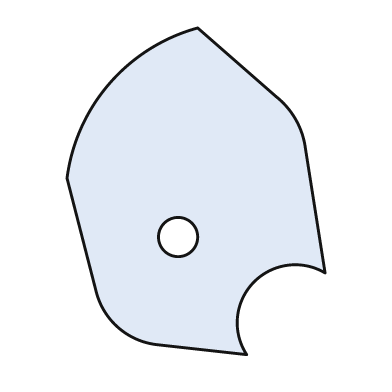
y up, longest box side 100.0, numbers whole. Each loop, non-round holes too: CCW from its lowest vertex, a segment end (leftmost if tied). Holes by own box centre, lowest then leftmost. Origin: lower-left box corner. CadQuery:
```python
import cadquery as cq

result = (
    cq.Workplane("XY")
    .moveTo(55.0, 0.0)
    .threePointArc((57.0, 22.0), (79.0, 25.0))
    .lineTo(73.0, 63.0)
    .threePointArc((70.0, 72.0), (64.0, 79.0))
    .lineTo(40.0, 100.0)
    .threePointArc((13.0, 83.0), (0.0, 54.0))
    .lineTo(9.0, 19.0)
    .threePointArc((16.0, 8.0), (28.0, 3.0))
    .close()
    .moveTo(34.0, 36.0)
    .circle(6.0)
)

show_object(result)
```